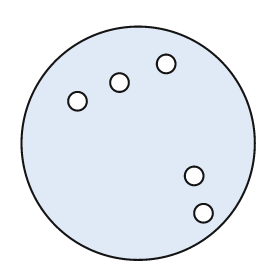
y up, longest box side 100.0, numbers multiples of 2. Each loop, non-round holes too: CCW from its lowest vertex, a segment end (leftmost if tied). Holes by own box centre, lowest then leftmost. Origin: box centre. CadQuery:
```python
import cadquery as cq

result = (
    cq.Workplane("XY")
    .moveTo(0.0, 0.0)
    .circle(50.0)
    .moveTo(28.0, -30.0)
    .circle(4.0)
    .moveTo(24.0, -14.0)
    .circle(4.0)
    .moveTo(-26.0, 18.0)
    .circle(4.0)
    .moveTo(-8.0, 26.0)
    .circle(4.0)
    .moveTo(12.0, 34.0)
    .circle(4.0)
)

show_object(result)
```